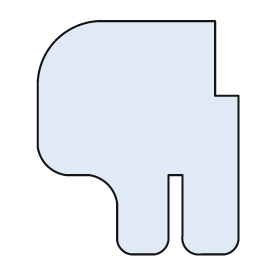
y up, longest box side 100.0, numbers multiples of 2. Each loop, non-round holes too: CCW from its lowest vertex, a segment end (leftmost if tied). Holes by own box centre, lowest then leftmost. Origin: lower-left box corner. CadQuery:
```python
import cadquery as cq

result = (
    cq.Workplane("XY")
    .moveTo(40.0, 0.0)
    .lineTo(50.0, 0.0)
    .threePointArc((54.0, 2.0), (56.0, 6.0))
    .lineTo(56.0, 34.0)
    .lineTo(62.0, 34.0)
    .lineTo(62.0, 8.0)
    .threePointArc((64.0, 2.0), (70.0, 0.0))
    .lineTo(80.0, 0.0)
    .threePointArc((84.0, 2.0), (86.0, 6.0))
    .lineTo(86.0, 68.0)
    .lineTo(76.0, 68.0)
    .lineTo(76.0, 100.0)
    .lineTo(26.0, 100.0)
    .threePointArc((8.0, 92.0), (0.0, 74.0))
    .lineTo(0.0, 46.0)
    .threePointArc((4.0, 38.0), (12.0, 34.0))
    .lineTo(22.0, 34.0)
    .threePointArc((30.0, 30.0), (34.0, 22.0))
    .lineTo(34.0, 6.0)
    .threePointArc((36.0, 2.0), (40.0, 0.0))
    .close()
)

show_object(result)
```